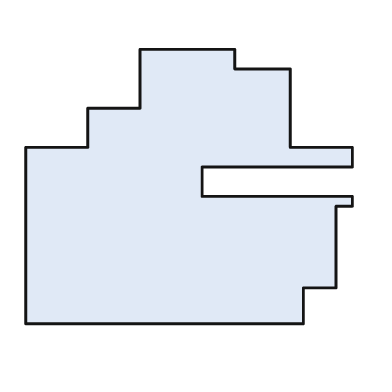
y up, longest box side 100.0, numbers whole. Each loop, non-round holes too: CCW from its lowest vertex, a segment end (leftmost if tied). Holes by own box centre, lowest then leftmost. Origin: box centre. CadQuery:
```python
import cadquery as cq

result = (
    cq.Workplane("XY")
    .moveTo(-50.0, -42.0)
    .lineTo(35.0, -42.0)
    .lineTo(35.0, -31.0)
    .lineTo(45.0, -31.0)
    .lineTo(45.0, -6.0)
    .lineTo(50.0, -6.0)
    .lineTo(50.0, -3.0)
    .lineTo(4.0, -3.0)
    .lineTo(4.0, 6.0)
    .lineTo(50.0, 6.0)
    .lineTo(50.0, 12.0)
    .lineTo(31.0, 12.0)
    .lineTo(31.0, 36.0)
    .lineTo(14.0, 36.0)
    .lineTo(14.0, 42.0)
    .lineTo(-15.0, 42.0)
    .lineTo(-15.0, 24.0)
    .lineTo(-31.0, 24.0)
    .lineTo(-31.0, 12.0)
    .lineTo(-50.0, 12.0)
    .close()
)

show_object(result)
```